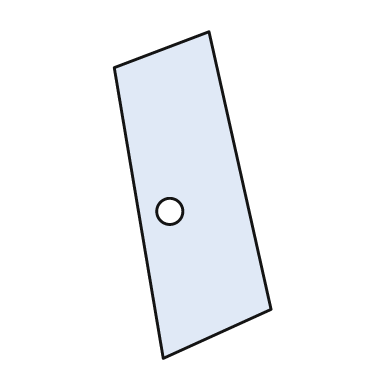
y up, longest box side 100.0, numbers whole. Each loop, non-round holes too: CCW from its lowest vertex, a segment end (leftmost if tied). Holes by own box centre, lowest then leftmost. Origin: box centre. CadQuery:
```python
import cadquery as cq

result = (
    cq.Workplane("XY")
    .moveTo(-9.0, -50.0)
    .lineTo(24.0, -35.0)
    .lineTo(5.0, 50.0)
    .lineTo(-24.0, 39.0)
    .close()
    .moveTo(-7.0, -5.0)
    .circle(4.0)
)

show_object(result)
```